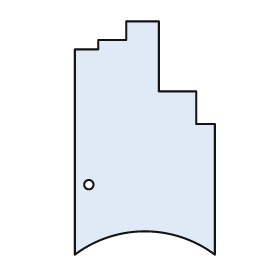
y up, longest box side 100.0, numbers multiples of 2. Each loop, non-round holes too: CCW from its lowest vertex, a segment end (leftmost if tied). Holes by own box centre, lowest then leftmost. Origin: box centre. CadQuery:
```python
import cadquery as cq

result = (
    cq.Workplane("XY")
    .moveTo(-30.0, -50.0)
    .threePointArc((0.0, -40.0), (30.0, -50.0))
    .lineTo(30.0, 6.0)
    .lineTo(22.0, 6.0)
    .lineTo(22.0, 20.0)
    .lineTo(6.0, 20.0)
    .lineTo(6.0, 50.0)
    .lineTo(-8.0, 50.0)
    .lineTo(-8.0, 42.0)
    .lineTo(-20.0, 42.0)
    .lineTo(-20.0, 38.0)
    .lineTo(-30.0, 38.0)
    .close()
    .moveTo(-24.0, -20.0)
    .circle(2.0)
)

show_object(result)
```